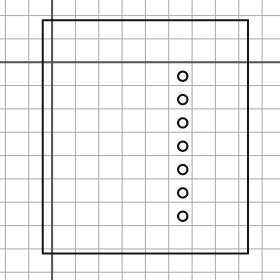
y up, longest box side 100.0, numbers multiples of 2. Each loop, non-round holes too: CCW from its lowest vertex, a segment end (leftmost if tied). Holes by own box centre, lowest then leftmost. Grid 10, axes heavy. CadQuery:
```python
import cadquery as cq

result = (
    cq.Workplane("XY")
    .moveTo(-4.0, -82.0)
    .lineTo(84.0, -82.0)
    .lineTo(84.0, 18.0)
    .lineTo(-4.0, 18.0)
    .close()
    .moveTo(56.0, -66.0)
    .circle(2.0)
    .moveTo(56.0, -56.0)
    .circle(2.0)
    .moveTo(56.0, -46.0)
    .circle(2.0)
    .moveTo(56.0, -36.0)
    .circle(2.0)
    .moveTo(56.0, -26.0)
    .circle(2.0)
    .moveTo(56.0, -16.0)
    .circle(2.0)
    .moveTo(56.0, -6.0)
    .circle(2.0)
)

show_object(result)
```